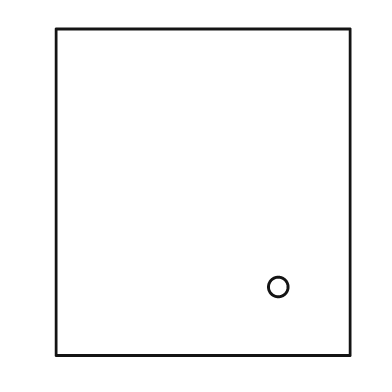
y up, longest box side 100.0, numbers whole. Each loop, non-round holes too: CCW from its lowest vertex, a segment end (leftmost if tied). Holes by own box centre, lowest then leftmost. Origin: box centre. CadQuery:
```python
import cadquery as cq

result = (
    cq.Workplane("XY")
    .moveTo(-45.0, -50.0)
    .lineTo(45.0, -50.0)
    .lineTo(45.0, 50.0)
    .lineTo(-45.0, 50.0)
    .close()
    .moveTo(23.0, -29.0)
    .circle(3.0)
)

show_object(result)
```